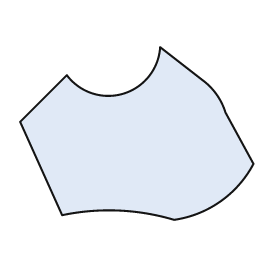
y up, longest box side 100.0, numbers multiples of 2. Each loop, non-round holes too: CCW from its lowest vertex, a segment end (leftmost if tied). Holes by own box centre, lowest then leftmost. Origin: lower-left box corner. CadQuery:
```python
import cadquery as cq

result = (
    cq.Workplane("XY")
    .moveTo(66.0, 0.0)
    .threePointArc((86.0, 8.0), (100.0, 24.0))
    .lineTo(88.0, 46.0)
    .threePointArc((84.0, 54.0), (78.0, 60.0))
    .lineTo(60.0, 74.0)
    .threePointArc((44.0, 54.0), (20.0, 62.0))
    .lineTo(0.0, 42.0)
    .lineTo(18.0, 2.0)
    .threePointArc((42.0, 4.0), (66.0, 0.0))
    .close()
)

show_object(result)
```